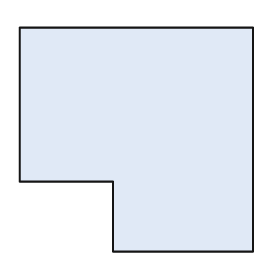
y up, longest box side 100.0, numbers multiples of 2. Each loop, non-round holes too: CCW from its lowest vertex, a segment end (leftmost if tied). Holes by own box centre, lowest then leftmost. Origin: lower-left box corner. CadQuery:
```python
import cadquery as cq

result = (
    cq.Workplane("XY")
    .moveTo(40.0, 0.0)
    .lineTo(100.0, 0.0)
    .lineTo(100.0, 96.0)
    .lineTo(0.0, 96.0)
    .lineTo(0.0, 30.0)
    .lineTo(40.0, 30.0)
    .close()
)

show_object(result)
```